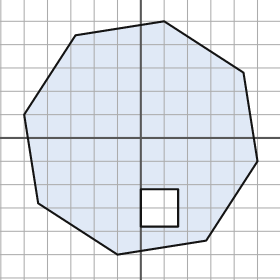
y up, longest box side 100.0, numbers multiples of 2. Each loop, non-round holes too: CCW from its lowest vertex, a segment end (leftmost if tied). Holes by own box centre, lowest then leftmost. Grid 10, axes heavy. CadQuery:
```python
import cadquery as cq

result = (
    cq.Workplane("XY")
    .moveTo(-10.0, -50.0)
    .lineTo(28.0, -44.0)
    .lineTo(50.0, -10.0)
    .lineTo(44.0, 28.0)
    .lineTo(10.0, 50.0)
    .lineTo(-28.0, 44.0)
    .lineTo(-50.0, 10.0)
    .lineTo(-44.0, -28.0)
    .close()
    .moveTo(0.0, -38.0)
    .lineTo(16.0, -38.0)
    .lineTo(16.0, -22.0)
    .lineTo(0.0, -22.0)
    .close()
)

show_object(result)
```